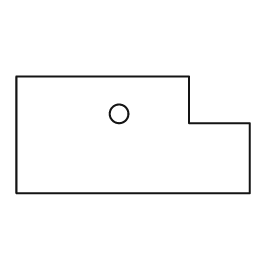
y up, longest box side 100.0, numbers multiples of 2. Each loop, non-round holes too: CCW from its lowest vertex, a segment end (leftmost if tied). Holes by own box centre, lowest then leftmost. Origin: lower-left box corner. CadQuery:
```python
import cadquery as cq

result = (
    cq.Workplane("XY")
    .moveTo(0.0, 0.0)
    .lineTo(100.0, 0.0)
    .lineTo(100.0, 30.0)
    .lineTo(74.0, 30.0)
    .lineTo(74.0, 50.0)
    .lineTo(0.0, 50.0)
    .close()
    .moveTo(44.0, 34.0)
    .circle(4.0)
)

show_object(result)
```